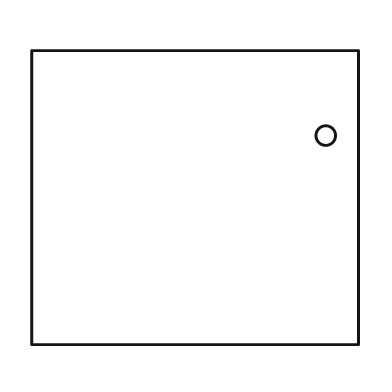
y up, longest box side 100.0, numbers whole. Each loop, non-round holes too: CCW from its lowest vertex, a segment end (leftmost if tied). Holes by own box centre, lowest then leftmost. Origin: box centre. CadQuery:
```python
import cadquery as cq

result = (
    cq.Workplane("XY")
    .moveTo(-50.0, -45.0)
    .lineTo(50.0, -45.0)
    .lineTo(50.0, 45.0)
    .lineTo(-50.0, 45.0)
    .close()
    .moveTo(40.0, 19.0)
    .circle(3.0)
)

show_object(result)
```